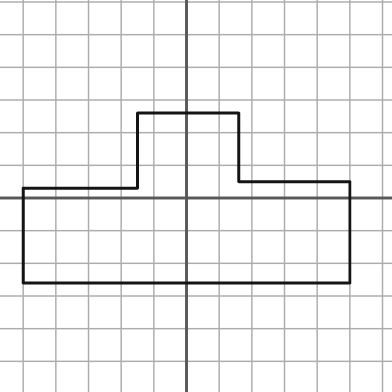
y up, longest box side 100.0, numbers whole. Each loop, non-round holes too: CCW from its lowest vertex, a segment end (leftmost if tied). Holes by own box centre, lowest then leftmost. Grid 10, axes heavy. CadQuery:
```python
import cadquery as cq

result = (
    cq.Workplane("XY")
    .moveTo(-50.0, -26.0)
    .lineTo(50.0, -26.0)
    .lineTo(50.0, 5.0)
    .lineTo(16.0, 5.0)
    .lineTo(16.0, 26.0)
    .lineTo(-15.0, 26.0)
    .lineTo(-15.0, 3.0)
    .lineTo(-50.0, 3.0)
    .close()
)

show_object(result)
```